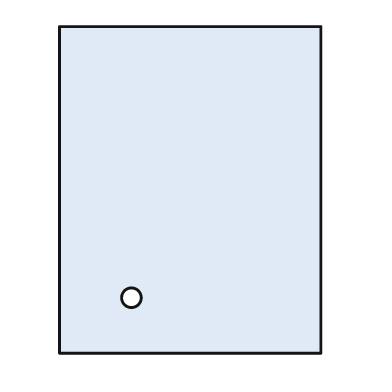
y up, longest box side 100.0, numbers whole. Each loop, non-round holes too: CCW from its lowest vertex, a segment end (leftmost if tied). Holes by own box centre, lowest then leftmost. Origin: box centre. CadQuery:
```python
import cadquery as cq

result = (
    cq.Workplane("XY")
    .moveTo(-40.0, -50.0)
    .lineTo(40.0, -50.0)
    .lineTo(40.0, 50.0)
    .lineTo(-40.0, 50.0)
    .close()
    .moveTo(-18.0, -33.0)
    .circle(3.0)
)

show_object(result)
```